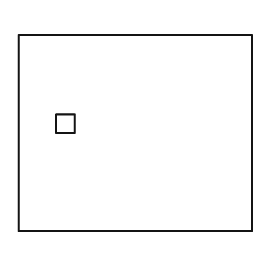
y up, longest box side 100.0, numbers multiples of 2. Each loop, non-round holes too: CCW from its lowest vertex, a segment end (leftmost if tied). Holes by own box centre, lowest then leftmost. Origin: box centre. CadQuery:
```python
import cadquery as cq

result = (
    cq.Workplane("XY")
    .moveTo(-50.0, -42.0)
    .lineTo(50.0, -42.0)
    .lineTo(50.0, 42.0)
    .lineTo(-50.0, 42.0)
    .close()
    .moveTo(-34.0, 0.0)
    .lineTo(-26.0, 0.0)
    .lineTo(-26.0, 8.0)
    .lineTo(-34.0, 8.0)
    .close()
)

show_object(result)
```